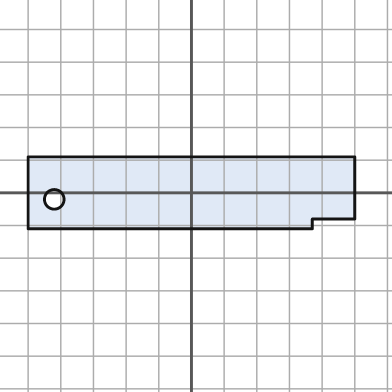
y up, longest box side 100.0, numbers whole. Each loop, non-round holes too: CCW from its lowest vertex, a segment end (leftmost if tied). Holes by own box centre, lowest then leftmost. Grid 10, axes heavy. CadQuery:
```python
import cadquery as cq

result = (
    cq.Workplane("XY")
    .moveTo(-50.0, -11.0)
    .lineTo(37.0, -11.0)
    .lineTo(37.0, -8.0)
    .lineTo(50.0, -8.0)
    .lineTo(50.0, 11.0)
    .lineTo(-50.0, 11.0)
    .close()
    .moveTo(-42.0, -2.0)
    .circle(3.0)
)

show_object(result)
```